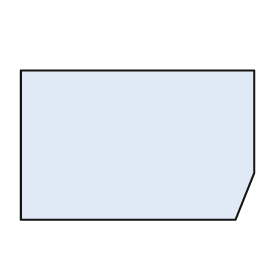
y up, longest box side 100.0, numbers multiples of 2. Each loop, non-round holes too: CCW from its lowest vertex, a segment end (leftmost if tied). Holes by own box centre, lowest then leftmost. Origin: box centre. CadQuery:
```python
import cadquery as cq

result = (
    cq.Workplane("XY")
    .moveTo(-50.0, -32.0)
    .lineTo(42.0, -32.0)
    .lineTo(50.0, -12.0)
    .lineTo(50.0, 32.0)
    .lineTo(-50.0, 32.0)
    .close()
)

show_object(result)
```